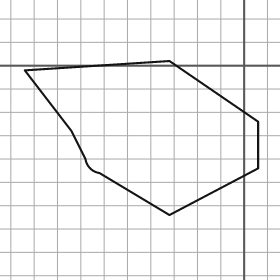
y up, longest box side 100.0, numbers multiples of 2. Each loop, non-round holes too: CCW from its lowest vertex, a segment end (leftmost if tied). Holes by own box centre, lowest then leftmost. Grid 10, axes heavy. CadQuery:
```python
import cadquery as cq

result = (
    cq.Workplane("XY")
    .moveTo(-32.0, -64.0)
    .lineTo(6.0, -44.0)
    .lineTo(6.0, -24.0)
    .lineTo(-32.0, 2.0)
    .lineTo(-94.0, -2.0)
    .lineTo(-74.0, -28.0)
    .lineTo(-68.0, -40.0)
    .threePointArc((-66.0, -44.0), (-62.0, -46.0))
    .close()
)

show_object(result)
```